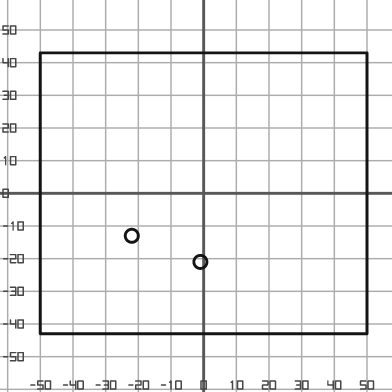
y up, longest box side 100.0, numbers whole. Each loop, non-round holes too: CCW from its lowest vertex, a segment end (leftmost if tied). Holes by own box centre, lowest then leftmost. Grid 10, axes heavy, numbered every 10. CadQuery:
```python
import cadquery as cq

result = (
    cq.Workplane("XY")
    .moveTo(-50.0, -43.0)
    .lineTo(50.0, -43.0)
    .lineTo(50.0, 43.0)
    .lineTo(-50.0, 43.0)
    .close()
    .moveTo(-1.0, -21.0)
    .circle(2.0)
    .moveTo(-22.0, -13.0)
    .circle(2.0)
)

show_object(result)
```